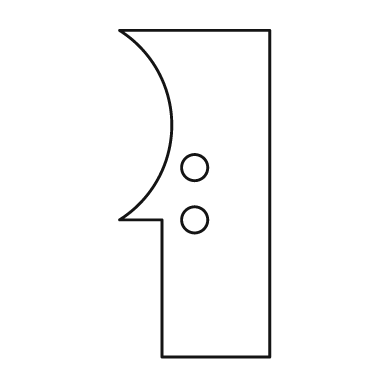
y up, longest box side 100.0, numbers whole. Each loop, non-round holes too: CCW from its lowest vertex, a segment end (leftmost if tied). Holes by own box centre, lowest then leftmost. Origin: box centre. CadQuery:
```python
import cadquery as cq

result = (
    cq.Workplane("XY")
    .moveTo(-10.0, -50.0)
    .lineTo(23.0, -50.0)
    .lineTo(23.0, 50.0)
    .lineTo(-23.0, 50.0)
    .threePointArc((-7.0, 21.0), (-23.0, -8.0))
    .lineTo(-10.0, -8.0)
    .close()
    .moveTo(0.0, -8.0)
    .circle(4.0)
    .moveTo(0.0, 8.0)
    .circle(4.0)
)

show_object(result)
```